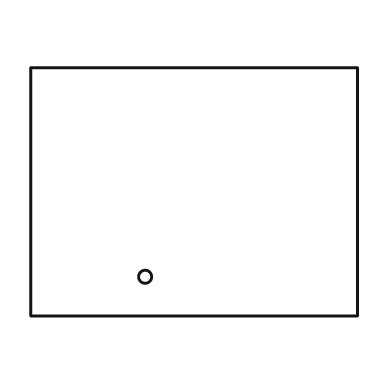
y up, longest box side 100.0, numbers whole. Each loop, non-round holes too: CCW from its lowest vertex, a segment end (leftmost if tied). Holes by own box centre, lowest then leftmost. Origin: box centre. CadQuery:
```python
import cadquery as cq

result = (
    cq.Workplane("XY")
    .moveTo(-50.0, -38.0)
    .lineTo(50.0, -38.0)
    .lineTo(50.0, 38.0)
    .lineTo(-50.0, 38.0)
    .close()
    .moveTo(-15.0, -26.0)
    .circle(2.0)
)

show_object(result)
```